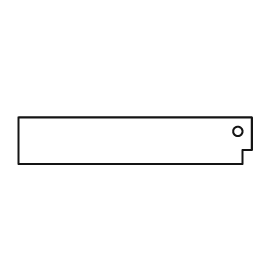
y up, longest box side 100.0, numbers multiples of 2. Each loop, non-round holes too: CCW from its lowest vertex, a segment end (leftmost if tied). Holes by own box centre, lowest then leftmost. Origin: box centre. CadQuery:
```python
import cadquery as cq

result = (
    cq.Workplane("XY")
    .moveTo(-50.0, -10.0)
    .lineTo(46.0, -10.0)
    .lineTo(46.0, -4.0)
    .lineTo(50.0, -4.0)
    .lineTo(50.0, 10.0)
    .lineTo(-50.0, 10.0)
    .close()
    .moveTo(44.0, 4.0)
    .circle(2.0)
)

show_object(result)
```